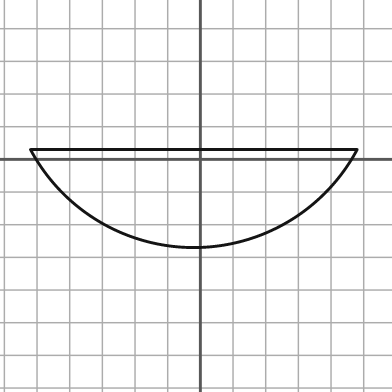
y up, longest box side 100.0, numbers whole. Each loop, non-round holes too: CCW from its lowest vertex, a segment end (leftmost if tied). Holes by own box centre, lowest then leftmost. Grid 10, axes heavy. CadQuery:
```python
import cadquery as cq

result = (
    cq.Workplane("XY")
    .moveTo(-52.0, 3.0)
    .threePointArc((-2.0, -27.0), (48.0, 3.0))
    .close()
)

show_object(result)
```